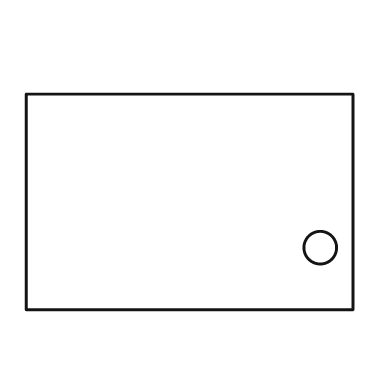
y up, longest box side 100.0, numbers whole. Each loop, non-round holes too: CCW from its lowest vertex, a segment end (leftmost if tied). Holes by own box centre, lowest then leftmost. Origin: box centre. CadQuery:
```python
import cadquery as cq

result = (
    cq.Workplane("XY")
    .moveTo(-50.0, -33.0)
    .lineTo(50.0, -33.0)
    .lineTo(50.0, 33.0)
    .lineTo(-50.0, 33.0)
    .close()
    .moveTo(40.0, -14.0)
    .circle(5.0)
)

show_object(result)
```